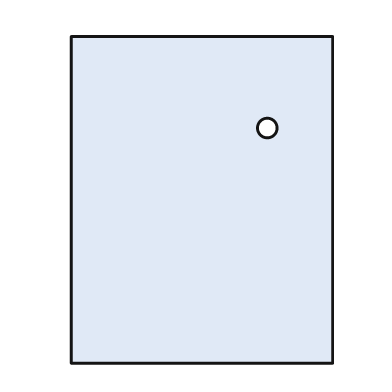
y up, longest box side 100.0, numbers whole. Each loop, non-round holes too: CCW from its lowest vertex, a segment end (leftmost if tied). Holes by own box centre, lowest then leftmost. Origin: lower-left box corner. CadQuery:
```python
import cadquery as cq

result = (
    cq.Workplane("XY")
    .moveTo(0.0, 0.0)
    .lineTo(80.0, 0.0)
    .lineTo(80.0, 100.0)
    .lineTo(0.0, 100.0)
    .close()
    .moveTo(60.0, 72.0)
    .circle(3.0)
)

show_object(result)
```